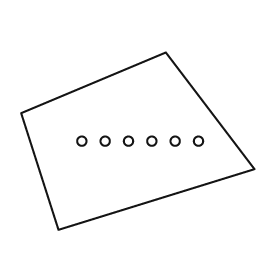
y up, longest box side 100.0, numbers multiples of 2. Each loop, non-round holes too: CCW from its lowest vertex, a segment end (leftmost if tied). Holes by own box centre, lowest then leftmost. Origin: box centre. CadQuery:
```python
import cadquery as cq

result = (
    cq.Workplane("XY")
    .moveTo(-34.0, -38.0)
    .lineTo(50.0, -12.0)
    .lineTo(12.0, 38.0)
    .lineTo(-50.0, 12.0)
    .close()
    .moveTo(-24.0, 0.0)
    .circle(2.0)
    .moveTo(-14.0, 0.0)
    .circle(2.0)
    .moveTo(-4.0, 0.0)
    .circle(2.0)
    .moveTo(6.0, 0.0)
    .circle(2.0)
    .moveTo(16.0, 0.0)
    .circle(2.0)
    .moveTo(26.0, 0.0)
    .circle(2.0)
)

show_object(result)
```